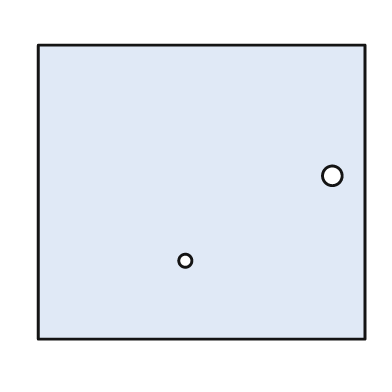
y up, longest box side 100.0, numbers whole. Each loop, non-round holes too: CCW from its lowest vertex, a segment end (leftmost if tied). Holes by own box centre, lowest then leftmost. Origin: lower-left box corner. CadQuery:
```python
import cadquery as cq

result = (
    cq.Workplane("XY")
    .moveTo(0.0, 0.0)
    .lineTo(100.0, 0.0)
    .lineTo(100.0, 90.0)
    .lineTo(0.0, 90.0)
    .close()
    .moveTo(45.0, 24.0)
    .circle(2.0)
    .moveTo(90.0, 50.0)
    .circle(3.0)
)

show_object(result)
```